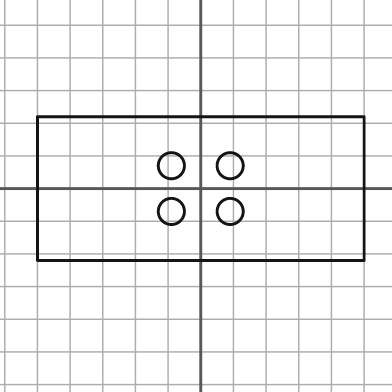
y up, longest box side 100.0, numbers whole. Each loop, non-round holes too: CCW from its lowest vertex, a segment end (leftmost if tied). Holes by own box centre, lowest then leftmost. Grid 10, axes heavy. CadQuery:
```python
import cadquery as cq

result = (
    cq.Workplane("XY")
    .moveTo(-50.0, -22.0)
    .lineTo(50.0, -22.0)
    .lineTo(50.0, 22.0)
    .lineTo(-50.0, 22.0)
    .close()
    .moveTo(-9.0, -7.0)
    .circle(4.0)
    .moveTo(9.0, -7.0)
    .circle(4.0)
    .moveTo(-9.0, 7.0)
    .circle(4.0)
    .moveTo(9.0, 7.0)
    .circle(4.0)
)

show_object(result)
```